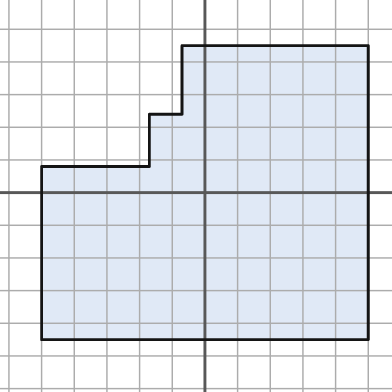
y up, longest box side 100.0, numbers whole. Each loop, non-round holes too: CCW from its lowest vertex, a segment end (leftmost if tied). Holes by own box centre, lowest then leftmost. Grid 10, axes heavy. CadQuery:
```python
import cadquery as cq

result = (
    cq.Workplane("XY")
    .moveTo(-50.0, -45.0)
    .lineTo(50.0, -45.0)
    .lineTo(50.0, 45.0)
    .lineTo(-7.0, 45.0)
    .lineTo(-7.0, 24.0)
    .lineTo(-17.0, 24.0)
    .lineTo(-17.0, 8.0)
    .lineTo(-50.0, 8.0)
    .close()
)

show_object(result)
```